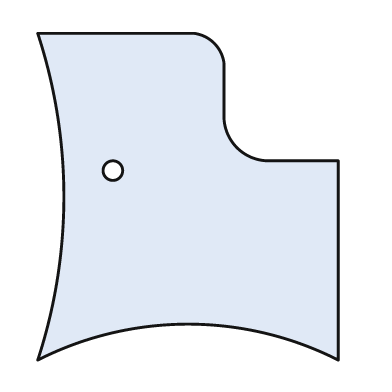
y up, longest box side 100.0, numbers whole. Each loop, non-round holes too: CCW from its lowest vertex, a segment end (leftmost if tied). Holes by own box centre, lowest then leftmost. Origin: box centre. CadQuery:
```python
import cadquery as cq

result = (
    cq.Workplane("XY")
    .moveTo(-46.0, -50.0)
    .threePointArc((0.0, -39.0), (46.0, -50.0))
    .lineTo(46.0, 11.0)
    .lineTo(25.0, 11.0)
    .threePointArc((15.0, 15.0), (11.0, 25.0))
    .lineTo(11.0, 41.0)
    .threePointArc((8.0, 47.0), (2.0, 50.0))
    .lineTo(-46.0, 50.0)
    .threePointArc((-38.0, 0.0), (-46.0, -50.0))
    .close()
    .moveTo(-23.0, 8.0)
    .circle(3.0)
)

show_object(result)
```